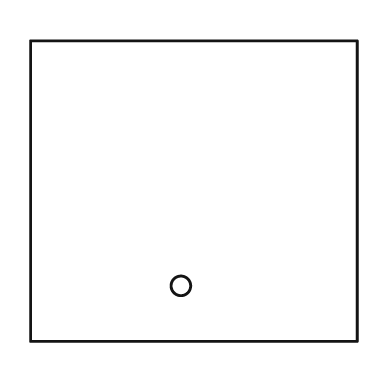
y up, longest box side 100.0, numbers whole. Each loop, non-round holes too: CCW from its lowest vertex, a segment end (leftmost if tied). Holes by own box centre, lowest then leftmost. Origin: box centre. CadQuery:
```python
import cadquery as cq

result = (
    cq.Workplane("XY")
    .moveTo(-50.0, -46.0)
    .lineTo(50.0, -46.0)
    .lineTo(50.0, 46.0)
    .lineTo(-50.0, 46.0)
    .close()
    .moveTo(-4.0, -29.0)
    .circle(3.0)
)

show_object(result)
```